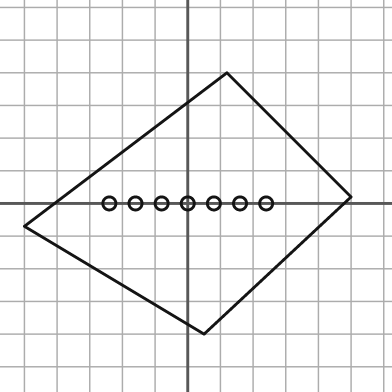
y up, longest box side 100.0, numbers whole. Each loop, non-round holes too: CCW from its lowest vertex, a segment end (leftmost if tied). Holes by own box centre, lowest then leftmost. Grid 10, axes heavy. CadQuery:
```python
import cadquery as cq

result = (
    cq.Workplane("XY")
    .moveTo(5.0, -40.0)
    .lineTo(50.0, 2.0)
    .lineTo(12.0, 40.0)
    .lineTo(-50.0, -7.0)
    .close()
    .moveTo(-24.0, 0.0)
    .circle(2.0)
    .moveTo(-16.0, 0.0)
    .circle(2.0)
    .moveTo(-8.0, 0.0)
    .circle(2.0)
    .moveTo(0.0, 0.0)
    .circle(2.0)
    .moveTo(8.0, 0.0)
    .circle(2.0)
    .moveTo(16.0, 0.0)
    .circle(2.0)
    .moveTo(24.0, 0.0)
    .circle(2.0)
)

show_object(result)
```